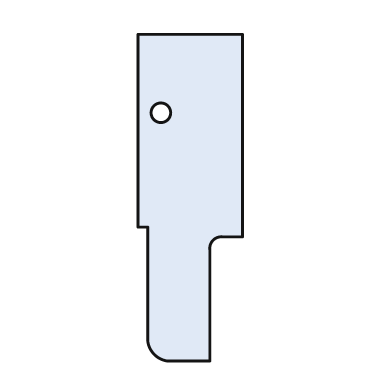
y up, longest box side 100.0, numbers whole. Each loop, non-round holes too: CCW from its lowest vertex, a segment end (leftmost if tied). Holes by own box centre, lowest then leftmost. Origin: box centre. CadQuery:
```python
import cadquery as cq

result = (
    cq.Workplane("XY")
    .moveTo(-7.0, -50.0)
    .lineTo(6.0, -50.0)
    .lineTo(6.0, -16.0)
    .threePointArc((7.0, -13.0), (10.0, -12.0))
    .lineTo(16.0, -12.0)
    .lineTo(16.0, 50.0)
    .lineTo(-16.0, 50.0)
    .lineTo(-16.0, -9.0)
    .lineTo(-13.0, -9.0)
    .lineTo(-13.0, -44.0)
    .threePointArc((-11.0, -48.0), (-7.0, -50.0))
    .close()
    .moveTo(-9.0, 26.0)
    .circle(3.0)
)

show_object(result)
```